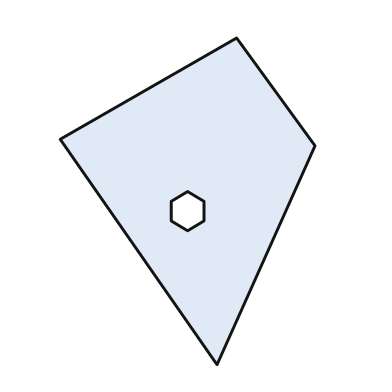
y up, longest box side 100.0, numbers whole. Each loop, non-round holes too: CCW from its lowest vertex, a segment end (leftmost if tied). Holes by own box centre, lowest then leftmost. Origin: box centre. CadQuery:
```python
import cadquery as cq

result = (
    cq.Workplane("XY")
    .moveTo(9.0, -50.0)
    .lineTo(39.0, 17.0)
    .lineTo(15.0, 50.0)
    .lineTo(-39.0, 19.0)
    .close()
    .moveTo(0.0, -9.0)
    .lineTo(5.0, -6.0)
    .lineTo(5.0, 0.0)
    .lineTo(0.0, 3.0)
    .lineTo(-5.0, 0.0)
    .lineTo(-5.0, -6.0)
    .close()
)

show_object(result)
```